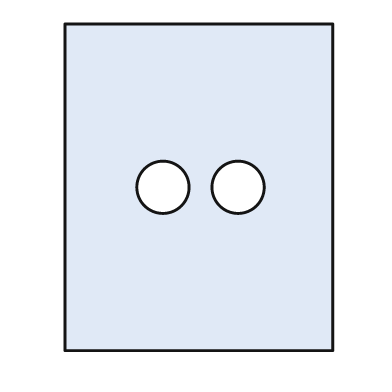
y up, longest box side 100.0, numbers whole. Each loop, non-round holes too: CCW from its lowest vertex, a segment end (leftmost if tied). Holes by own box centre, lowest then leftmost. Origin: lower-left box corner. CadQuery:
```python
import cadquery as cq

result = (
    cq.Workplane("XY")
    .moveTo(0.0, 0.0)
    .lineTo(82.0, 0.0)
    .lineTo(82.0, 100.0)
    .lineTo(0.0, 100.0)
    .close()
    .moveTo(30.0, 50.0)
    .circle(8.0)
    .moveTo(53.0, 50.0)
    .circle(8.0)
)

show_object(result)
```